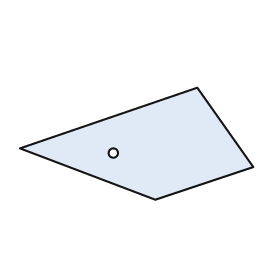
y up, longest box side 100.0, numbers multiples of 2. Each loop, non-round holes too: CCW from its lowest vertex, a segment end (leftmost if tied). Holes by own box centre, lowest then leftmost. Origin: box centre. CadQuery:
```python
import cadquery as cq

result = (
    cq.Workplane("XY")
    .moveTo(8.0, -24.0)
    .lineTo(50.0, -10.0)
    .lineTo(26.0, 24.0)
    .lineTo(-50.0, -2.0)
    .close()
    .moveTo(-10.0, -4.0)
    .circle(2.0)
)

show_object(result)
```